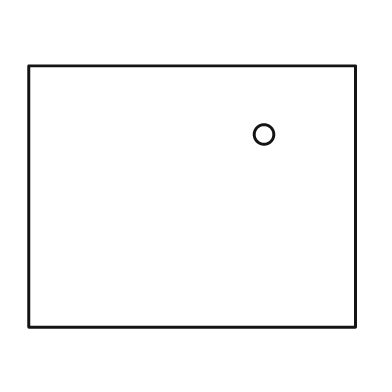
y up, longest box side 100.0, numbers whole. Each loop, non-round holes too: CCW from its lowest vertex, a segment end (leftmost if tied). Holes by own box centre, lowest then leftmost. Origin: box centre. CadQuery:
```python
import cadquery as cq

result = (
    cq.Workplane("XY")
    .moveTo(-50.0, -40.0)
    .lineTo(50.0, -40.0)
    .lineTo(50.0, 40.0)
    .lineTo(-50.0, 40.0)
    .close()
    .moveTo(22.0, 19.0)
    .circle(3.0)
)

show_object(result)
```